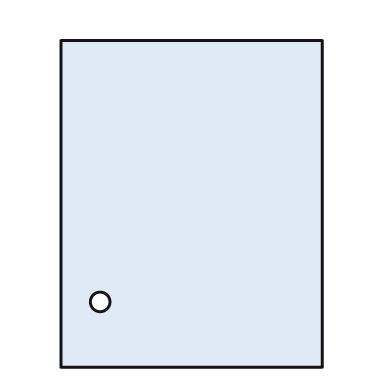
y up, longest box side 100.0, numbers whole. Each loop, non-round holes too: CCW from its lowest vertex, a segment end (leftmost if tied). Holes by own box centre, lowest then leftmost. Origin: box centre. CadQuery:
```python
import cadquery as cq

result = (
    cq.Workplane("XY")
    .moveTo(-40.0, -50.0)
    .lineTo(40.0, -50.0)
    .lineTo(40.0, 50.0)
    .lineTo(-40.0, 50.0)
    .close()
    .moveTo(-28.0, -30.0)
    .circle(3.0)
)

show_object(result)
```